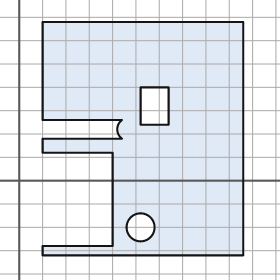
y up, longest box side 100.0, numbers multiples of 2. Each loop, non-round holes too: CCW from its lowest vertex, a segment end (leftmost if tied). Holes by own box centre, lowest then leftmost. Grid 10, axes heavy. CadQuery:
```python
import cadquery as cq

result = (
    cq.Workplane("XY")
    .moveTo(10.0, -32.0)
    .lineTo(96.0, -32.0)
    .lineTo(96.0, 68.0)
    .lineTo(10.0, 68.0)
    .lineTo(10.0, 26.0)
    .lineTo(44.0, 26.0)
    .threePointArc((42.0, 22.0), (44.0, 18.0))
    .lineTo(10.0, 18.0)
    .lineTo(10.0, 12.0)
    .lineTo(40.0, 12.0)
    .lineTo(40.0, -28.0)
    .lineTo(10.0, -28.0)
    .close()
    .moveTo(52.0, -20.0)
    .circle(6.0)
    .moveTo(52.0, 24.0)
    .lineTo(64.0, 24.0)
    .lineTo(64.0, 40.0)
    .lineTo(52.0, 40.0)
    .close()
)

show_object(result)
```